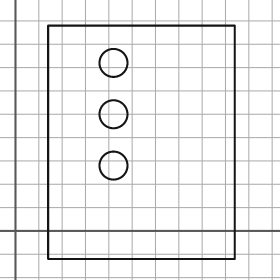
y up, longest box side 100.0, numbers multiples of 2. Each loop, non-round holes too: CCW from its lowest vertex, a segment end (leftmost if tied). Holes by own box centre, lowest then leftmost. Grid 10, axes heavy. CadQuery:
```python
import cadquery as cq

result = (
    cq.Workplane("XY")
    .moveTo(14.0, -12.0)
    .lineTo(94.0, -12.0)
    .lineTo(94.0, 88.0)
    .lineTo(14.0, 88.0)
    .close()
    .moveTo(42.0, 28.0)
    .circle(6.0)
    .moveTo(42.0, 50.0)
    .circle(6.0)
    .moveTo(42.0, 72.0)
    .circle(6.0)
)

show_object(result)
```